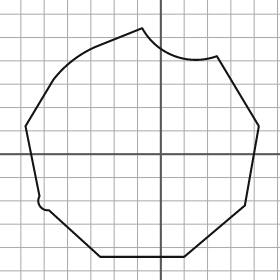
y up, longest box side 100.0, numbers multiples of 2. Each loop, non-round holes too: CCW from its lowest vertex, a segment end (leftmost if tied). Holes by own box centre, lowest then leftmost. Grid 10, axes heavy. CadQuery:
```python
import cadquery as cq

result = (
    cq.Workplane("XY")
    .moveTo(-26.0, -44.0)
    .lineTo(10.0, -44.0)
    .lineTo(36.0, -22.0)
    .lineTo(42.0, 12.0)
    .lineTo(24.0, 42.0)
    .threePointArc((6.0, 42.0), (-8.0, 54.0))
    .lineTo(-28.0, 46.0)
    .threePointArc((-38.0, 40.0), (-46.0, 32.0))
    .lineTo(-58.0, 12.0)
    .lineTo(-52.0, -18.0)
    .threePointArc((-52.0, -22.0), (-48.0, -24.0))
    .close()
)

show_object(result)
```